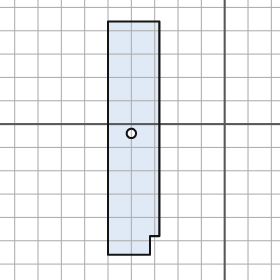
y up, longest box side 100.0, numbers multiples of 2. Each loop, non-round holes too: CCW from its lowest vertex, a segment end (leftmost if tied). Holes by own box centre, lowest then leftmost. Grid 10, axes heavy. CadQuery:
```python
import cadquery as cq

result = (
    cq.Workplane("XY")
    .moveTo(-50.0, -56.0)
    .lineTo(-32.0, -56.0)
    .lineTo(-32.0, -48.0)
    .lineTo(-28.0, -48.0)
    .lineTo(-28.0, 44.0)
    .lineTo(-50.0, 44.0)
    .close()
    .moveTo(-40.0, -4.0)
    .circle(2.0)
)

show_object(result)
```